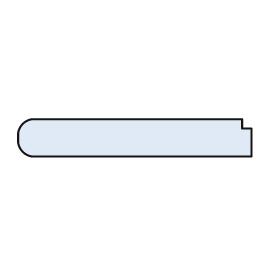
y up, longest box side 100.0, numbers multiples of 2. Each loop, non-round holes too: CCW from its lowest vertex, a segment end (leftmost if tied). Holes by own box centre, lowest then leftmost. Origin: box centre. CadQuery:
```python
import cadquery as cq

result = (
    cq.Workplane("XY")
    .moveTo(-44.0, -8.0)
    .lineTo(50.0, -8.0)
    .lineTo(50.0, 4.0)
    .lineTo(46.0, 4.0)
    .lineTo(46.0, 8.0)
    .lineTo(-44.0, 8.0)
    .threePointArc((-48.0, 6.0), (-50.0, 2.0))
    .lineTo(-50.0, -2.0)
    .threePointArc((-48.0, -6.0), (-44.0, -8.0))
    .close()
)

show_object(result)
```